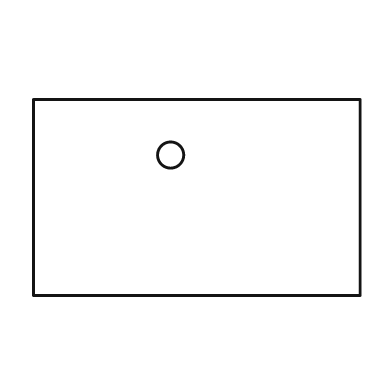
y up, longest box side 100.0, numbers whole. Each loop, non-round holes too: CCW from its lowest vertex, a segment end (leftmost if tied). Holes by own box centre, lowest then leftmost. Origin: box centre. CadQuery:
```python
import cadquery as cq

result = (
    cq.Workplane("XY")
    .moveTo(-50.0, -30.0)
    .lineTo(50.0, -30.0)
    .lineTo(50.0, 30.0)
    .lineTo(-50.0, 30.0)
    .close()
    .moveTo(-8.0, 13.0)
    .circle(4.0)
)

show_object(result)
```